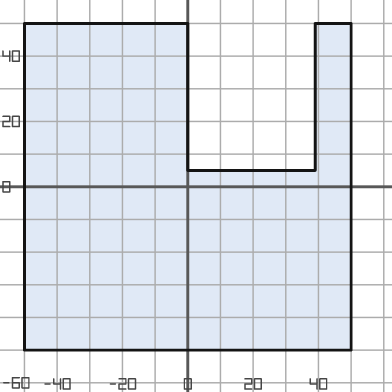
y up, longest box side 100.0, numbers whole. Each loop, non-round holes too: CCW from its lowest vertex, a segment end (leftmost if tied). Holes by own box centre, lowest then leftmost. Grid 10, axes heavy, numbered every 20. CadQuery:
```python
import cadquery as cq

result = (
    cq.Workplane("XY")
    .moveTo(-50.0, -50.0)
    .lineTo(50.0, -50.0)
    .lineTo(50.0, 50.0)
    .lineTo(39.0, 50.0)
    .lineTo(39.0, 5.0)
    .lineTo(0.0, 5.0)
    .lineTo(0.0, 50.0)
    .lineTo(-50.0, 50.0)
    .close()
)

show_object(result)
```